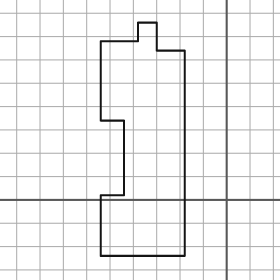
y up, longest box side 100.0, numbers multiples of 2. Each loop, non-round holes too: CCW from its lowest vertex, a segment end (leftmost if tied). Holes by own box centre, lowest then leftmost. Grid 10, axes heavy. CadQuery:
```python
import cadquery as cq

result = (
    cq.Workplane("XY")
    .moveTo(-54.0, -24.0)
    .lineTo(-18.0, -24.0)
    .lineTo(-18.0, 64.0)
    .lineTo(-30.0, 64.0)
    .lineTo(-30.0, 76.0)
    .lineTo(-38.0, 76.0)
    .lineTo(-38.0, 68.0)
    .lineTo(-54.0, 68.0)
    .lineTo(-54.0, 34.0)
    .lineTo(-44.0, 34.0)
    .lineTo(-44.0, 2.0)
    .lineTo(-54.0, 2.0)
    .close()
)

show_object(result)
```